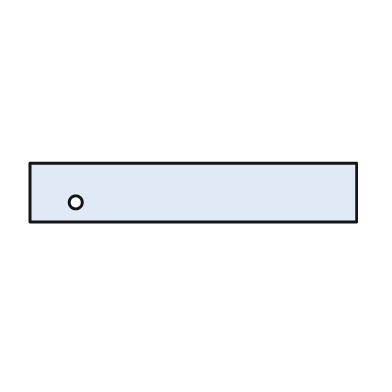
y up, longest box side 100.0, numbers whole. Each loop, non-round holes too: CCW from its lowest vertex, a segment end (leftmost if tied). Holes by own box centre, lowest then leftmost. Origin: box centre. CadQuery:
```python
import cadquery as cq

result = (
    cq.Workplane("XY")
    .moveTo(-50.0, -9.0)
    .lineTo(50.0, -9.0)
    .lineTo(50.0, 9.0)
    .lineTo(-50.0, 9.0)
    .close()
    .moveTo(-36.0, -3.0)
    .circle(2.0)
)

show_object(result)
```